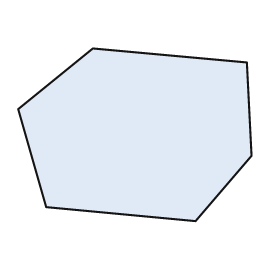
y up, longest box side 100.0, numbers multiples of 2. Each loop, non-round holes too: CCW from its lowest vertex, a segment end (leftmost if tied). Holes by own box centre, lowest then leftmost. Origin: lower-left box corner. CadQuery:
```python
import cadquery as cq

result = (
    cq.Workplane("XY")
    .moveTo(76.0, 0.0)
    .lineTo(100.0, 28.0)
    .lineTo(98.0, 68.0)
    .lineTo(32.0, 74.0)
    .lineTo(0.0, 48.0)
    .lineTo(12.0, 6.0)
    .close()
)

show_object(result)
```